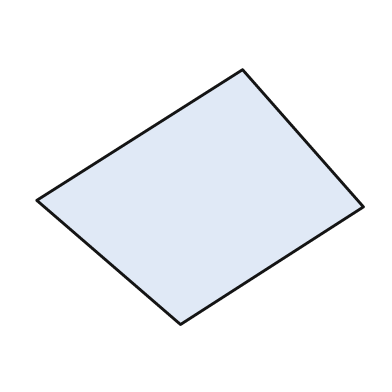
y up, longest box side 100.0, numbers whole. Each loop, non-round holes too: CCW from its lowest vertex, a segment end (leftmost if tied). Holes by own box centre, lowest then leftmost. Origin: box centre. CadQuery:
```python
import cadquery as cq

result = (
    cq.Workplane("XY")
    .moveTo(-6.0, -39.0)
    .lineTo(50.0, -3.0)
    .lineTo(13.0, 39.0)
    .lineTo(-50.0, -1.0)
    .close()
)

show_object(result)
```